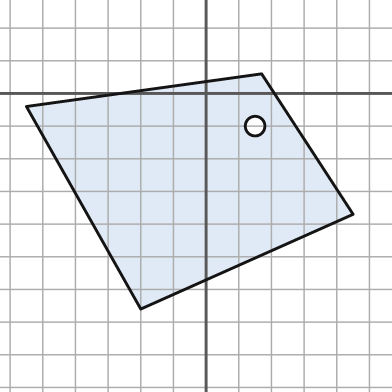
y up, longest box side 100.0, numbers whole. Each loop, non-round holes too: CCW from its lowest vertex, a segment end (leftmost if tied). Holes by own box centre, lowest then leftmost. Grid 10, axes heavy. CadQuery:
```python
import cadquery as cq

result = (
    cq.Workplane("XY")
    .moveTo(-20.0, -66.0)
    .lineTo(45.0, -37.0)
    .lineTo(17.0, 6.0)
    .lineTo(-55.0, -4.0)
    .close()
    .moveTo(15.0, -10.0)
    .circle(3.0)
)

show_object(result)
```